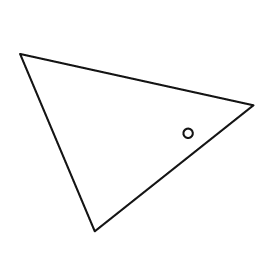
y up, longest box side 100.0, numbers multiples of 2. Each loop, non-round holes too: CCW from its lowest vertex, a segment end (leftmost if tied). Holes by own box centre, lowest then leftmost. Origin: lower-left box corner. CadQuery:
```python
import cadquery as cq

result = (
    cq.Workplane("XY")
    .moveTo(32.0, 0.0)
    .lineTo(100.0, 54.0)
    .lineTo(0.0, 76.0)
    .close()
    .moveTo(72.0, 42.0)
    .circle(2.0)
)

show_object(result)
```